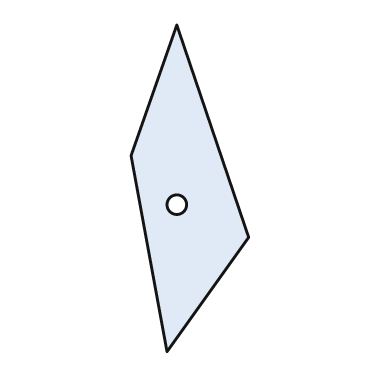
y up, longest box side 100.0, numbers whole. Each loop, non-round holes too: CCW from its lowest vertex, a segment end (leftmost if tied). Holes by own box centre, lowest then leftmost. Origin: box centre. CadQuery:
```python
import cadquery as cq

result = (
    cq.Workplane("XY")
    .moveTo(-7.0, -50.0)
    .lineTo(18.0, -15.0)
    .lineTo(-4.0, 50.0)
    .lineTo(-18.0, 10.0)
    .close()
    .moveTo(-4.0, -5.0)
    .circle(3.0)
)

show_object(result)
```